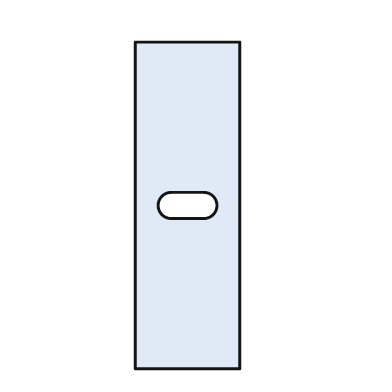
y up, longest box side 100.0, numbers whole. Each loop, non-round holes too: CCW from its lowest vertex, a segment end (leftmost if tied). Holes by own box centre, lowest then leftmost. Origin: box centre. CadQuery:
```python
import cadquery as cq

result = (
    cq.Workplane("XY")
    .moveTo(-16.0, -50.0)
    .lineTo(16.0, -50.0)
    .lineTo(16.0, 50.0)
    .lineTo(-16.0, 50.0)
    .close()
    .moveTo(-5.0, -4.0)
    .lineTo(5.0, -4.0)
    .threePointArc((9.0, 0.0), (5.0, 4.0))
    .lineTo(-5.0, 4.0)
    .threePointArc((-9.0, 0.0), (-5.0, -4.0))
    .close()
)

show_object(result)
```